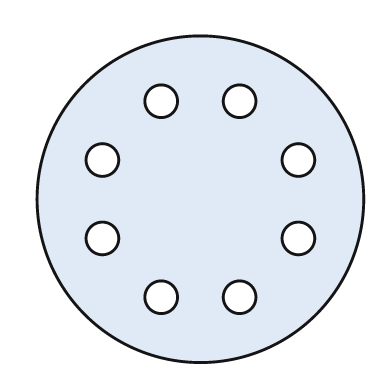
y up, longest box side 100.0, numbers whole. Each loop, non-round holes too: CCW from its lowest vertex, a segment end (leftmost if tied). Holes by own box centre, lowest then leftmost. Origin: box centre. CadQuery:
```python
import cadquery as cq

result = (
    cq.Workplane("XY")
    .moveTo(0.0, 0.0)
    .circle(50.0)
    .moveTo(-12.0, -30.0)
    .circle(5.0)
    .moveTo(12.0, -30.0)
    .circle(5.0)
    .moveTo(-30.0, -12.0)
    .circle(5.0)
    .moveTo(30.0, -12.0)
    .circle(5.0)
    .moveTo(-30.0, 12.0)
    .circle(5.0)
    .moveTo(30.0, 12.0)
    .circle(5.0)
    .moveTo(-12.0, 30.0)
    .circle(5.0)
    .moveTo(12.0, 30.0)
    .circle(5.0)
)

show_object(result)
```